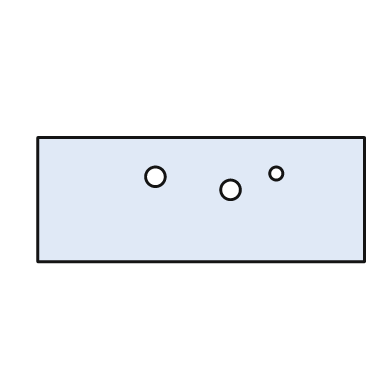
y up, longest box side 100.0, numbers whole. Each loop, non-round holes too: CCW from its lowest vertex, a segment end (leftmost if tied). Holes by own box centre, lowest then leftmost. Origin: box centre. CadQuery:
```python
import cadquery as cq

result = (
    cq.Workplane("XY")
    .moveTo(-50.0, -19.0)
    .lineTo(50.0, -19.0)
    .lineTo(50.0, 19.0)
    .lineTo(-50.0, 19.0)
    .close()
    .moveTo(9.0, 3.0)
    .circle(3.0)
    .moveTo(-14.0, 7.0)
    .circle(3.0)
    .moveTo(23.0, 8.0)
    .circle(2.0)
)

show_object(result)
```